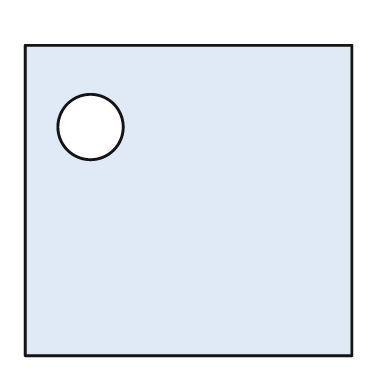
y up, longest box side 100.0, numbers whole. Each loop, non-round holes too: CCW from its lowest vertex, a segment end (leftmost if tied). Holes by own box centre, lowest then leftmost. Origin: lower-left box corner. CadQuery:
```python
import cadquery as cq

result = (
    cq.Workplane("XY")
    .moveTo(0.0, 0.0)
    .lineTo(100.0, 0.0)
    .lineTo(100.0, 95.0)
    .lineTo(0.0, 95.0)
    .close()
    .moveTo(20.0, 70.0)
    .circle(10.0)
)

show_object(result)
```